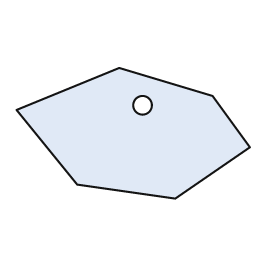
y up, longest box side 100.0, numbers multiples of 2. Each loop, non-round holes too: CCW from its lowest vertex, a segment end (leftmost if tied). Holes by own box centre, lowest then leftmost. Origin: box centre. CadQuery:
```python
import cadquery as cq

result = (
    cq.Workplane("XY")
    .moveTo(18.0, -28.0)
    .lineTo(50.0, -6.0)
    .lineTo(34.0, 16.0)
    .lineTo(-6.0, 28.0)
    .lineTo(-50.0, 10.0)
    .lineTo(-24.0, -22.0)
    .close()
    .moveTo(4.0, 12.0)
    .circle(4.0)
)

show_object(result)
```